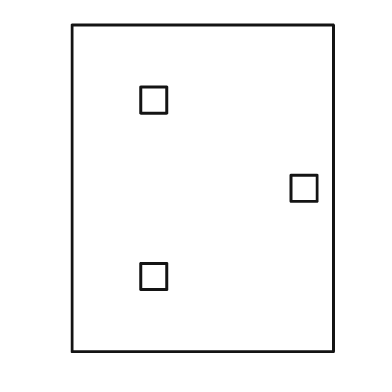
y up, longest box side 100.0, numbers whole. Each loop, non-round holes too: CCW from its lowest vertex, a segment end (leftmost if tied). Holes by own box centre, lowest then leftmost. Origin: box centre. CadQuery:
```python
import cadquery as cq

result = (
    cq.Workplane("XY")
    .moveTo(-40.0, -50.0)
    .lineTo(40.0, -50.0)
    .lineTo(40.0, 50.0)
    .lineTo(-40.0, 50.0)
    .close()
    .moveTo(-19.0, -31.0)
    .lineTo(-11.0, -31.0)
    .lineTo(-11.0, -23.0)
    .lineTo(-19.0, -23.0)
    .close()
    .moveTo(27.0, -4.0)
    .lineTo(35.0, -4.0)
    .lineTo(35.0, 4.0)
    .lineTo(27.0, 4.0)
    .close()
    .moveTo(-19.0, 23.0)
    .lineTo(-11.0, 23.0)
    .lineTo(-11.0, 31.0)
    .lineTo(-19.0, 31.0)
    .close()
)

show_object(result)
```